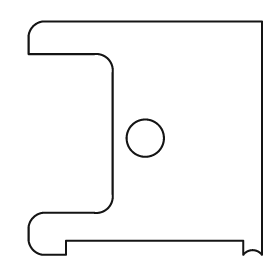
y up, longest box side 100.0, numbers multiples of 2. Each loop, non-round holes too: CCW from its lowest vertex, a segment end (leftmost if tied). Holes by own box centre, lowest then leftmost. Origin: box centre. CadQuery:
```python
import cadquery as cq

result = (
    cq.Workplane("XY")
    .moveTo(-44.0, -50.0)
    .lineTo(-34.0, -50.0)
    .lineTo(-34.0, -44.0)
    .lineTo(42.0, -44.0)
    .lineTo(42.0, -50.0)
    .threePointArc((46.0, -48.0), (50.0, -50.0))
    .lineTo(50.0, 50.0)
    .lineTo(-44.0, 50.0)
    .threePointArc((-48.0, 48.0), (-50.0, 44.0))
    .lineTo(-50.0, 36.0)
    .lineTo(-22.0, 36.0)
    .threePointArc((-16.0, 34.0), (-14.0, 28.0))
    .lineTo(-14.0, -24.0)
    .threePointArc((-16.0, -30.0), (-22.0, -32.0))
    .lineTo(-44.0, -32.0)
    .threePointArc((-48.0, -34.0), (-50.0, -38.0))
    .lineTo(-50.0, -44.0)
    .threePointArc((-48.0, -48.0), (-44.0, -50.0))
    .close()
    .moveTo(0.0, 0.0)
    .circle(8.0)
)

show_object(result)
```